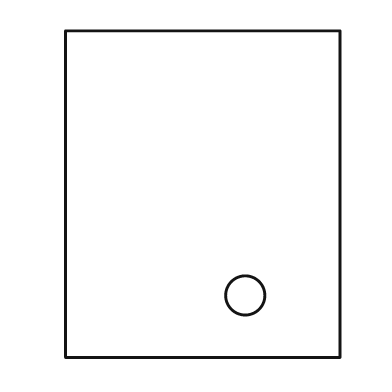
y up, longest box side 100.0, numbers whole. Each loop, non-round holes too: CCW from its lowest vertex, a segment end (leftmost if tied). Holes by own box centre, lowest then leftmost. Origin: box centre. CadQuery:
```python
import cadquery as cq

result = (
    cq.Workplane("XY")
    .moveTo(-42.0, -50.0)
    .lineTo(42.0, -50.0)
    .lineTo(42.0, 50.0)
    .lineTo(-42.0, 50.0)
    .close()
    .moveTo(13.0, -31.0)
    .circle(6.0)
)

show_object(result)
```